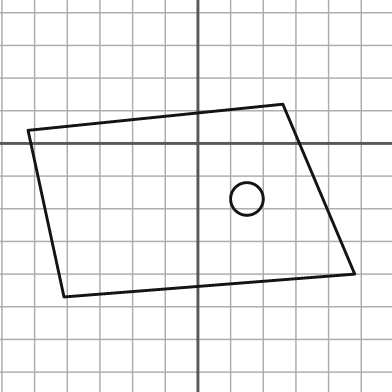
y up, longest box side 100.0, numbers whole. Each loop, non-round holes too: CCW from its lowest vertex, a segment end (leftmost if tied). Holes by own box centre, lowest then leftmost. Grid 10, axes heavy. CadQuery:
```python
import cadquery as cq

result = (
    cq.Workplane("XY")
    .moveTo(-41.0, -47.0)
    .lineTo(48.0, -40.0)
    .lineTo(26.0, 12.0)
    .lineTo(-52.0, 4.0)
    .close()
    .moveTo(15.0, -17.0)
    .circle(5.0)
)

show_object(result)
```